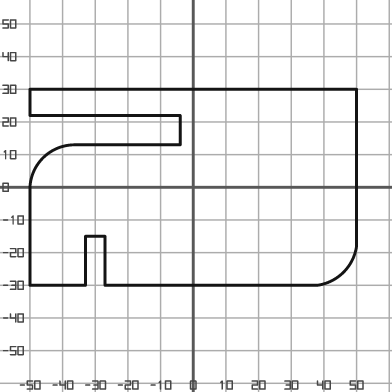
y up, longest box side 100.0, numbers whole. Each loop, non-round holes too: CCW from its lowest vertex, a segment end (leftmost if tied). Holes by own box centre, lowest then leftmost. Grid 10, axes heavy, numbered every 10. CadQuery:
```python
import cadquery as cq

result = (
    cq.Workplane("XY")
    .moveTo(-50.0, -30.0)
    .lineTo(-33.0, -30.0)
    .lineTo(-33.0, -15.0)
    .lineTo(-27.0, -15.0)
    .lineTo(-27.0, -30.0)
    .lineTo(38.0, -30.0)
    .threePointArc((46.0, -26.0), (50.0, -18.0))
    .lineTo(50.0, 30.0)
    .lineTo(-50.0, 30.0)
    .lineTo(-50.0, 22.0)
    .lineTo(-4.0, 22.0)
    .lineTo(-4.0, 13.0)
    .lineTo(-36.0, 13.0)
    .threePointArc((-46.0, 9.0), (-50.0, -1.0))
    .close()
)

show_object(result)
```